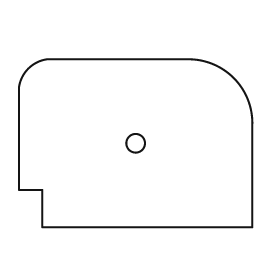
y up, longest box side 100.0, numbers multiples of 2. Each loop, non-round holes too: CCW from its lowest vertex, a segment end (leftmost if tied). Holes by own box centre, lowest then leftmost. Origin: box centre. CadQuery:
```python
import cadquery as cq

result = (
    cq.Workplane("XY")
    .moveTo(-40.0, -36.0)
    .lineTo(50.0, -36.0)
    .lineTo(50.0, 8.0)
    .threePointArc((42.0, 28.0), (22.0, 36.0))
    .lineTo(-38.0, 36.0)
    .threePointArc((-46.0, 32.0), (-50.0, 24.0))
    .lineTo(-50.0, -20.0)
    .lineTo(-40.0, -20.0)
    .close()
    .moveTo(0.0, 0.0)
    .circle(4.0)
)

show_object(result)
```